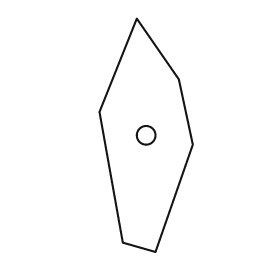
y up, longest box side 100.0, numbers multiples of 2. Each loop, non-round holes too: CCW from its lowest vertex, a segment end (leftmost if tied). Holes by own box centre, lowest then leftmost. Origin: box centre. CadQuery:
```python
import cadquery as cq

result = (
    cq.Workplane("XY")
    .moveTo(4.0, -50.0)
    .lineTo(20.0, -4.0)
    .lineTo(14.0, 24.0)
    .lineTo(-4.0, 50.0)
    .lineTo(-20.0, 10.0)
    .lineTo(-10.0, -46.0)
    .close()
    .moveTo(0.0, 0.0)
    .circle(4.0)
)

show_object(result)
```